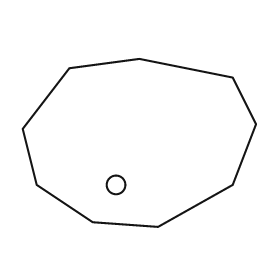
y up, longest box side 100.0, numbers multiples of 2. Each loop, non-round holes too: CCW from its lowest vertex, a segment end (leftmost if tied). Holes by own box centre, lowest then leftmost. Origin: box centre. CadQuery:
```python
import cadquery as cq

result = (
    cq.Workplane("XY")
    .moveTo(8.0, -36.0)
    .lineTo(40.0, -18.0)
    .lineTo(50.0, 8.0)
    .lineTo(40.0, 28.0)
    .lineTo(0.0, 36.0)
    .lineTo(-30.0, 32.0)
    .lineTo(-50.0, 6.0)
    .lineTo(-44.0, -18.0)
    .lineTo(-20.0, -34.0)
    .close()
    .moveTo(-10.0, -18.0)
    .circle(4.0)
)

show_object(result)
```